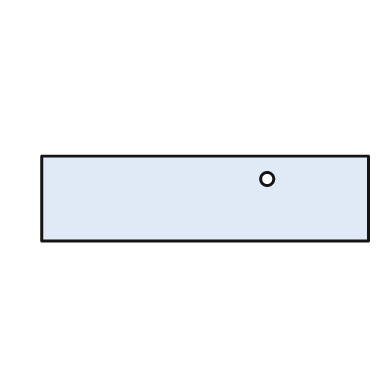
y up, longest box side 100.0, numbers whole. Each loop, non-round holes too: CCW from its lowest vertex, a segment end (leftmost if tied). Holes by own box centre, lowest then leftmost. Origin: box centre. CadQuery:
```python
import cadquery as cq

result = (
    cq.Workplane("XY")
    .moveTo(-50.0, -13.0)
    .lineTo(50.0, -13.0)
    .lineTo(50.0, 13.0)
    .lineTo(-50.0, 13.0)
    .close()
    .moveTo(19.0, 6.0)
    .circle(2.0)
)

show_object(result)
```